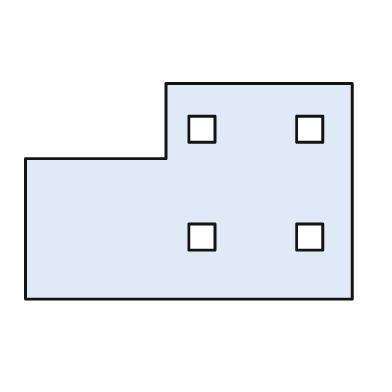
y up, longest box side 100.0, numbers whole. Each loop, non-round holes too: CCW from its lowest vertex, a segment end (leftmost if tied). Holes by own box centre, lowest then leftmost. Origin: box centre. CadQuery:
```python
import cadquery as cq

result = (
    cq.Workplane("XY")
    .moveTo(-50.0, -33.0)
    .lineTo(50.0, -33.0)
    .lineTo(50.0, 33.0)
    .lineTo(-7.0, 33.0)
    .lineTo(-7.0, 10.0)
    .lineTo(-50.0, 10.0)
    .close()
    .moveTo(0.0, -18.0)
    .lineTo(8.0, -18.0)
    .lineTo(8.0, -10.0)
    .lineTo(0.0, -10.0)
    .close()
    .moveTo(33.0, -18.0)
    .lineTo(41.0, -18.0)
    .lineTo(41.0, -10.0)
    .lineTo(33.0, -10.0)
    .close()
    .moveTo(0.0, 15.0)
    .lineTo(8.0, 15.0)
    .lineTo(8.0, 23.0)
    .lineTo(0.0, 23.0)
    .close()
    .moveTo(33.0, 15.0)
    .lineTo(41.0, 15.0)
    .lineTo(41.0, 23.0)
    .lineTo(33.0, 23.0)
    .close()
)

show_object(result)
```